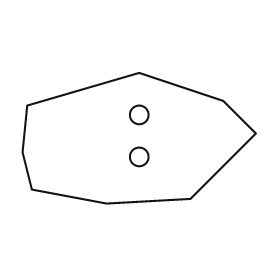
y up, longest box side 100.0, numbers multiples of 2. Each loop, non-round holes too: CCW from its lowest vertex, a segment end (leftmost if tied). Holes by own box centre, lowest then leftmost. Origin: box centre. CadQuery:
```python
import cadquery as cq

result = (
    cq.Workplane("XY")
    .moveTo(-14.0, -28.0)
    .lineTo(22.0, -26.0)
    .lineTo(50.0, 2.0)
    .lineTo(36.0, 16.0)
    .lineTo(0.0, 28.0)
    .lineTo(-48.0, 14.0)
    .lineTo(-50.0, -6.0)
    .lineTo(-46.0, -22.0)
    .close()
    .moveTo(0.0, -8.0)
    .circle(4.0)
    .moveTo(0.0, 10.0)
    .circle(4.0)
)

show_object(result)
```